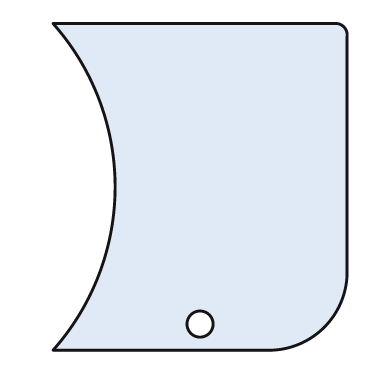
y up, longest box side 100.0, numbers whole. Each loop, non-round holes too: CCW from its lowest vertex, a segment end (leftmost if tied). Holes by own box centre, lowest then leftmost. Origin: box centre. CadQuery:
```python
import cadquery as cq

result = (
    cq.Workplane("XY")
    .moveTo(-45.0, -50.0)
    .lineTo(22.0, -50.0)
    .threePointArc((38.0, -43.0), (45.0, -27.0))
    .lineTo(45.0, 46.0)
    .threePointArc((44.0, 49.0), (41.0, 50.0))
    .lineTo(-45.0, 50.0)
    .threePointArc((-26.0, 0.0), (-45.0, -50.0))
    .close()
    .moveTo(0.0, -42.0)
    .circle(4.0)
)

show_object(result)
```